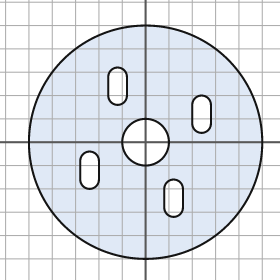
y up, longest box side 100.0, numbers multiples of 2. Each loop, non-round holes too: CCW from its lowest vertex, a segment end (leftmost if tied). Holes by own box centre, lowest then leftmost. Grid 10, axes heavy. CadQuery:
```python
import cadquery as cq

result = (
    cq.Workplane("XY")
    .moveTo(0.0, 0.0)
    .circle(50.0)
    .moveTo(8.0, -28.0)
    .threePointArc((12.0, -32.0), (16.0, -28.0))
    .lineTo(16.0, -20.0)
    .threePointArc((12.0, -16.0), (8.0, -20.0))
    .close()
    .moveTo(-28.0, -16.0)
    .threePointArc((-24.0, -20.0), (-20.0, -16.0))
    .lineTo(-20.0, -8.0)
    .threePointArc((-24.0, -4.0), (-28.0, -8.0))
    .close()
    .moveTo(0.0, 0.0)
    .circle(10.0)
    .moveTo(20.0, 8.0)
    .threePointArc((24.0, 4.0), (28.0, 8.0))
    .lineTo(28.0, 16.0)
    .threePointArc((24.0, 20.0), (20.0, 16.0))
    .close()
    .moveTo(-16.0, 20.0)
    .threePointArc((-12.0, 16.0), (-8.0, 20.0))
    .lineTo(-8.0, 28.0)
    .threePointArc((-12.0, 32.0), (-16.0, 28.0))
    .close()
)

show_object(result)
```